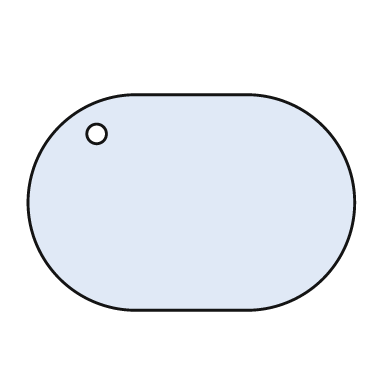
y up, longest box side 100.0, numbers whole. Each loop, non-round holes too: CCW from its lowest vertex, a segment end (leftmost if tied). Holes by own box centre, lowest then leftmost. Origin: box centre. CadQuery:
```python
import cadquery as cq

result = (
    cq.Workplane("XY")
    .moveTo(-17.0, -33.0)
    .lineTo(17.0, -33.0)
    .threePointArc((50.0, 0.0), (17.0, 33.0))
    .lineTo(-17.0, 33.0)
    .threePointArc((-50.0, 0.0), (-17.0, -33.0))
    .close()
    .moveTo(-29.0, 21.0)
    .circle(3.0)
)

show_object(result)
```